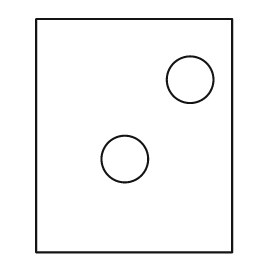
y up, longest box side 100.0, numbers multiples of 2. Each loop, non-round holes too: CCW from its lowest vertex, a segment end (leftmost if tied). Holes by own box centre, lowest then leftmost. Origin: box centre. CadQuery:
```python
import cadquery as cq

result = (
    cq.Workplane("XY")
    .moveTo(-42.0, -50.0)
    .lineTo(42.0, -50.0)
    .lineTo(42.0, 50.0)
    .lineTo(-42.0, 50.0)
    .close()
    .moveTo(-4.0, -10.0)
    .circle(10.0)
    .moveTo(24.0, 24.0)
    .circle(10.0)
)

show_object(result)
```